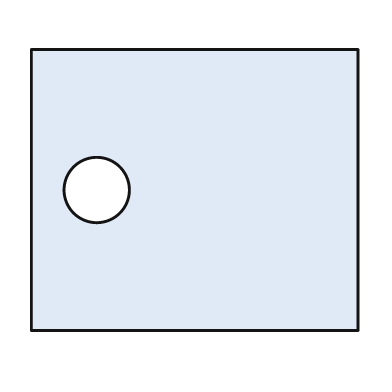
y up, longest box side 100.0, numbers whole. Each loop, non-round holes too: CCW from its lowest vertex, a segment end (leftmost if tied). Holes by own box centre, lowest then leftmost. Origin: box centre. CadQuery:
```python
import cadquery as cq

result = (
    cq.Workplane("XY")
    .moveTo(-50.0, -43.0)
    .lineTo(50.0, -43.0)
    .lineTo(50.0, 43.0)
    .lineTo(-50.0, 43.0)
    .close()
    .moveTo(-30.0, 0.0)
    .circle(10.0)
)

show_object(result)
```